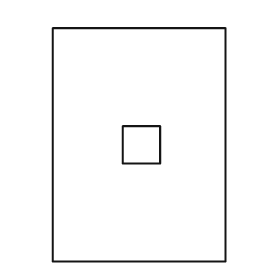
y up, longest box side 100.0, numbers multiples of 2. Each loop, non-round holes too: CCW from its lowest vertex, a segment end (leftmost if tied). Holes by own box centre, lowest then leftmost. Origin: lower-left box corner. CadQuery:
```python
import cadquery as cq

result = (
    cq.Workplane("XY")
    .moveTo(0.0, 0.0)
    .lineTo(74.0, 0.0)
    .lineTo(74.0, 100.0)
    .lineTo(0.0, 100.0)
    .close()
    .moveTo(30.0, 42.0)
    .lineTo(46.0, 42.0)
    .lineTo(46.0, 58.0)
    .lineTo(30.0, 58.0)
    .close()
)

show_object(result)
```